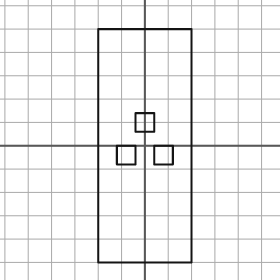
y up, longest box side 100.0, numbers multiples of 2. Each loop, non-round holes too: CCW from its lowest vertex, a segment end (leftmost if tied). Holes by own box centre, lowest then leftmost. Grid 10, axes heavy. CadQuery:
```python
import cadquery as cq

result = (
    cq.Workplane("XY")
    .moveTo(-20.0, -50.0)
    .lineTo(20.0, -50.0)
    .lineTo(20.0, 50.0)
    .lineTo(-20.0, 50.0)
    .close()
    .moveTo(-12.0, -8.0)
    .lineTo(-4.0, -8.0)
    .lineTo(-4.0, 0.0)
    .lineTo(-12.0, 0.0)
    .close()
    .moveTo(4.0, -8.0)
    .lineTo(12.0, -8.0)
    .lineTo(12.0, 0.0)
    .lineTo(4.0, 0.0)
    .close()
    .moveTo(-4.0, 6.0)
    .lineTo(4.0, 6.0)
    .lineTo(4.0, 14.0)
    .lineTo(-4.0, 14.0)
    .close()
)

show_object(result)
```